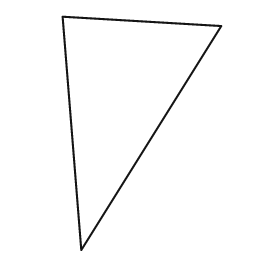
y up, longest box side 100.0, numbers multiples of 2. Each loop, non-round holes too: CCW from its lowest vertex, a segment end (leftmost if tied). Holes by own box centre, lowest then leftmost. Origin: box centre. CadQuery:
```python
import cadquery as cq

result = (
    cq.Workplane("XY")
    .moveTo(-26.0, -50.0)
    .lineTo(34.0, 46.0)
    .lineTo(-34.0, 50.0)
    .close()
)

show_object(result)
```